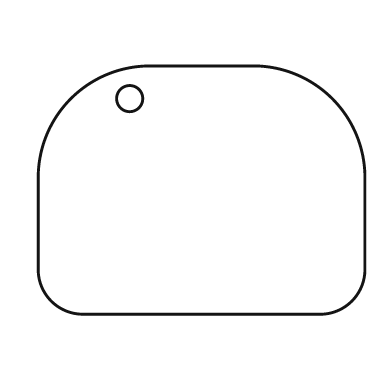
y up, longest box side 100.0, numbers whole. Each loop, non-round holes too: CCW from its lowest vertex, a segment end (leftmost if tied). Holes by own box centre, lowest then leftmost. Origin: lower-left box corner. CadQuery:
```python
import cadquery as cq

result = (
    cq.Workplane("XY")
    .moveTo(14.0, 0.0)
    .lineTo(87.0, 0.0)
    .threePointArc((96.0, 4.0), (100.0, 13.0))
    .lineTo(100.0, 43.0)
    .threePointArc((90.0, 66.0), (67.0, 76.0))
    .lineTo(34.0, 76.0)
    .threePointArc((10.0, 66.0), (0.0, 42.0))
    .lineTo(0.0, 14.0)
    .threePointArc((4.0, 4.0), (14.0, 0.0))
    .close()
    .moveTo(28.0, 66.0)
    .circle(4.0)
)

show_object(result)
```